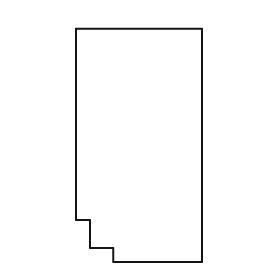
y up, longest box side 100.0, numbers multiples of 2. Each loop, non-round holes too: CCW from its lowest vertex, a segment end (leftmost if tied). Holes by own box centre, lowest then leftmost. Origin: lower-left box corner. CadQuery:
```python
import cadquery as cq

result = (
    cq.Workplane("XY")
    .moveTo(16.0, 0.0)
    .lineTo(54.0, 0.0)
    .lineTo(54.0, 100.0)
    .lineTo(0.0, 100.0)
    .lineTo(0.0, 18.0)
    .lineTo(6.0, 18.0)
    .lineTo(6.0, 6.0)
    .lineTo(16.0, 6.0)
    .close()
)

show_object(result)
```